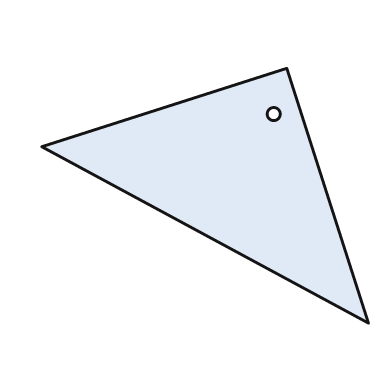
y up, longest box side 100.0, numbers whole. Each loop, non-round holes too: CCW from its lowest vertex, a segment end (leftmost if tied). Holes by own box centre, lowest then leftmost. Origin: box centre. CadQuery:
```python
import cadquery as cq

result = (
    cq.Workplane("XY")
    .moveTo(50.0, -39.0)
    .lineTo(25.0, 39.0)
    .lineTo(-50.0, 15.0)
    .close()
    .moveTo(21.0, 25.0)
    .circle(2.0)
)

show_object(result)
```